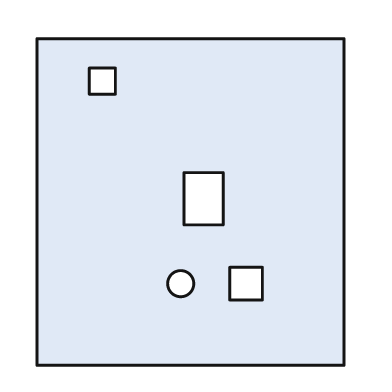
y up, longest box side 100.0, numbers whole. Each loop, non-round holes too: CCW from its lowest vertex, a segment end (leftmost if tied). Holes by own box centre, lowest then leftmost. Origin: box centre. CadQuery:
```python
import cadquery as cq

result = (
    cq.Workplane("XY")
    .moveTo(-47.0, -50.0)
    .lineTo(47.0, -50.0)
    .lineTo(47.0, 50.0)
    .lineTo(-47.0, 50.0)
    .close()
    .moveTo(-3.0, -25.0)
    .circle(4.0)
    .moveTo(12.0, -30.0)
    .lineTo(22.0, -30.0)
    .lineTo(22.0, -20.0)
    .lineTo(12.0, -20.0)
    .close()
    .moveTo(-2.0, -7.0)
    .lineTo(10.0, -7.0)
    .lineTo(10.0, 9.0)
    .lineTo(-2.0, 9.0)
    .close()
    .moveTo(-31.0, 33.0)
    .lineTo(-23.0, 33.0)
    .lineTo(-23.0, 41.0)
    .lineTo(-31.0, 41.0)
    .close()
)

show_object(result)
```